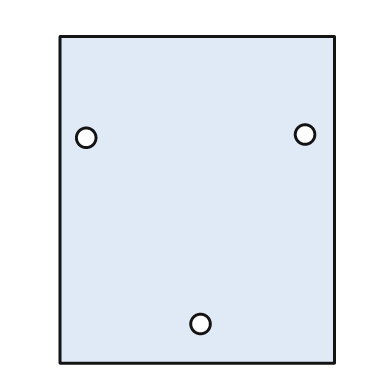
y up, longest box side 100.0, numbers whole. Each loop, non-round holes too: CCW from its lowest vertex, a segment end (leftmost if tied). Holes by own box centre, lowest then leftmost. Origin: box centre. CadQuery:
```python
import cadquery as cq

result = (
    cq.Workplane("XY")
    .moveTo(-42.0, -50.0)
    .lineTo(42.0, -50.0)
    .lineTo(42.0, 50.0)
    .lineTo(-42.0, 50.0)
    .close()
    .moveTo(1.0, -38.0)
    .circle(3.0)
    .moveTo(-34.0, 19.0)
    .circle(3.0)
    .moveTo(33.0, 20.0)
    .circle(3.0)
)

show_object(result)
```